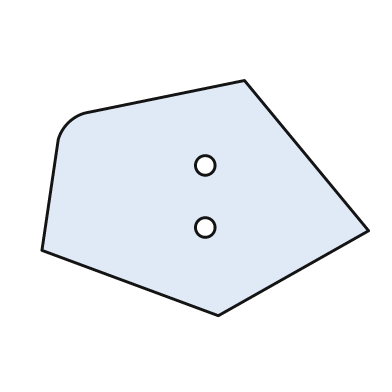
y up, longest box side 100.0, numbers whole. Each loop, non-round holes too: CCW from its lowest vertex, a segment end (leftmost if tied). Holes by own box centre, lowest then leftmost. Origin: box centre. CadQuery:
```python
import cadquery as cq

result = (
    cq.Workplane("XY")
    .moveTo(4.0, -36.0)
    .lineTo(50.0, -10.0)
    .lineTo(12.0, 36.0)
    .lineTo(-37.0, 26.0)
    .threePointArc((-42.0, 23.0), (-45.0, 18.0))
    .lineTo(-50.0, -16.0)
    .close()
    .moveTo(0.0, -9.0)
    .circle(3.0)
    .moveTo(0.0, 10.0)
    .circle(3.0)
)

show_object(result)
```